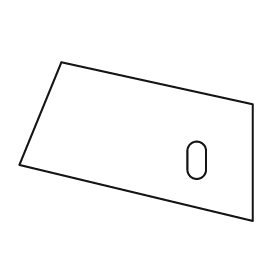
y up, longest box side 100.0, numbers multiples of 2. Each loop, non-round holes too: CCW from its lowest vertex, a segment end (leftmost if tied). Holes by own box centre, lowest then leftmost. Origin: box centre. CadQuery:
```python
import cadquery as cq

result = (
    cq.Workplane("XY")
    .moveTo(50.0, -34.0)
    .lineTo(50.0, 16.0)
    .lineTo(-32.0, 34.0)
    .lineTo(-50.0, -10.0)
    .close()
    .moveTo(22.0, -12.0)
    .threePointArc((26.0, -16.0), (30.0, -12.0))
    .lineTo(30.0, -4.0)
    .threePointArc((26.0, 0.0), (22.0, -4.0))
    .close()
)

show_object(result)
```